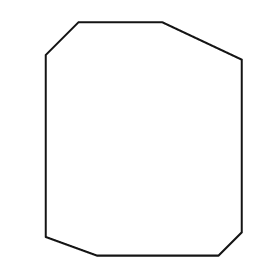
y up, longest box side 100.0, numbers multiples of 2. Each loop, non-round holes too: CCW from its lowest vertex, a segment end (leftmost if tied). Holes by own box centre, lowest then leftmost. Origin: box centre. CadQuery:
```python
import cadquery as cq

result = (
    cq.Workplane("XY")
    .moveTo(-20.0, -50.0)
    .lineTo(32.0, -50.0)
    .lineTo(42.0, -40.0)
    .lineTo(42.0, 34.0)
    .lineTo(8.0, 50.0)
    .lineTo(-28.0, 50.0)
    .lineTo(-42.0, 36.0)
    .lineTo(-42.0, -42.0)
    .close()
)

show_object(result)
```